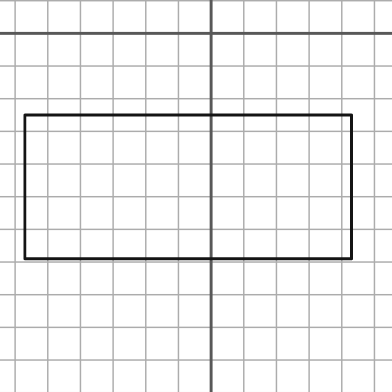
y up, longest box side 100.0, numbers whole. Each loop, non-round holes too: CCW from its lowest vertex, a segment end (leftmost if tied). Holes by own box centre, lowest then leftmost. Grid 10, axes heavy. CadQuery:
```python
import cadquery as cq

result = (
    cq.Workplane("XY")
    .moveTo(-57.0, -69.0)
    .lineTo(43.0, -69.0)
    .lineTo(43.0, -25.0)
    .lineTo(-57.0, -25.0)
    .close()
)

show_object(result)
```